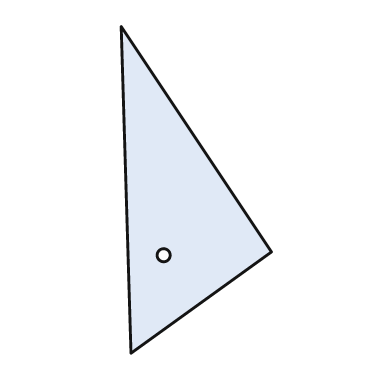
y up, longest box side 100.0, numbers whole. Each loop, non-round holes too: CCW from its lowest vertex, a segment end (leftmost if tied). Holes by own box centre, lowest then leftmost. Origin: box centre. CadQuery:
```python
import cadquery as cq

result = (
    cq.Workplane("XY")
    .moveTo(-20.0, -50.0)
    .lineTo(23.0, -19.0)
    .lineTo(-23.0, 50.0)
    .close()
    .moveTo(-10.0, -20.0)
    .circle(2.0)
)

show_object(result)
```